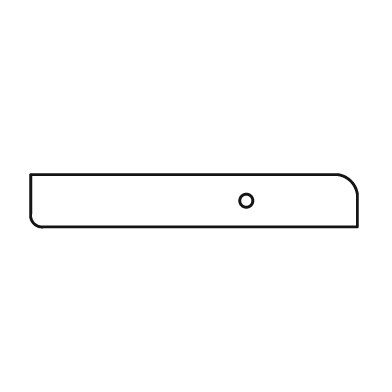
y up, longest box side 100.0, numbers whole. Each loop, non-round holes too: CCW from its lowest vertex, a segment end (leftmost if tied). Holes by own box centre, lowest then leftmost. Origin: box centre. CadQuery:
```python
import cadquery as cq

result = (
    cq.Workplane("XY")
    .moveTo(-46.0, -8.0)
    .lineTo(50.0, -8.0)
    .lineTo(50.0, 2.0)
    .threePointArc((48.0, 6.0), (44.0, 8.0))
    .lineTo(-50.0, 8.0)
    .lineTo(-50.0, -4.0)
    .threePointArc((-49.0, -7.0), (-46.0, -8.0))
    .close()
    .moveTo(16.0, 0.0)
    .circle(2.0)
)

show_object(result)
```